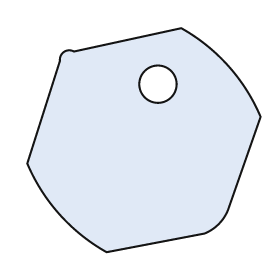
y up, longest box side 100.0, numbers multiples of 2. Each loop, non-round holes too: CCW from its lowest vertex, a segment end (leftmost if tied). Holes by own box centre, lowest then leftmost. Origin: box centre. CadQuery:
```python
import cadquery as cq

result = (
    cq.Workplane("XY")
    .moveTo(-16.0, -48.0)
    .lineTo(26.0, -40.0)
    .threePointArc((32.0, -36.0), (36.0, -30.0))
    .lineTo(50.0, 10.0)
    .threePointArc((36.0, 32.0), (16.0, 48.0))
    .lineTo(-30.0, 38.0)
    .threePointArc((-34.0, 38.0), (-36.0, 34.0))
    .lineTo(-50.0, -10.0)
    .threePointArc((-36.0, -32.0), (-16.0, -48.0))
    .close()
    .moveTo(6.0, 24.0)
    .circle(8.0)
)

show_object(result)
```